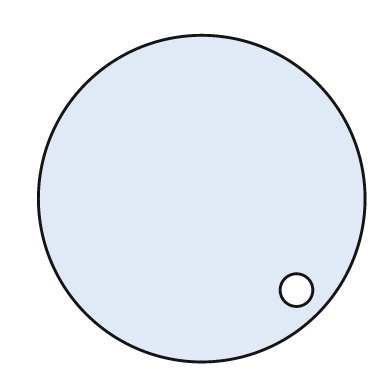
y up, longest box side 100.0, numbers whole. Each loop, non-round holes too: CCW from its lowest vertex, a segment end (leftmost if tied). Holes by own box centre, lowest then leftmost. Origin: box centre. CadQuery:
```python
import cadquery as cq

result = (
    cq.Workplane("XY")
    .moveTo(0.0, 0.0)
    .circle(50.0)
    .moveTo(29.0, -28.0)
    .circle(5.0)
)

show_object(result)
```